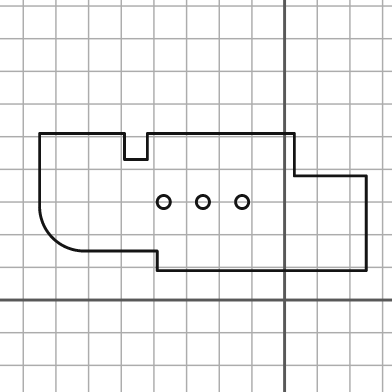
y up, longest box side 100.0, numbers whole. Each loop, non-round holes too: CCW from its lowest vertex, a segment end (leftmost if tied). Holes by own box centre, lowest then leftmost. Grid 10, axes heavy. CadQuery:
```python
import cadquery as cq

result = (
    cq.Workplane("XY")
    .moveTo(-39.0, 9.0)
    .lineTo(25.0, 9.0)
    .lineTo(25.0, 38.0)
    .lineTo(3.0, 38.0)
    .lineTo(3.0, 51.0)
    .lineTo(-42.0, 51.0)
    .lineTo(-42.0, 43.0)
    .lineTo(-49.0, 43.0)
    .lineTo(-49.0, 51.0)
    .lineTo(-75.0, 51.0)
    .lineTo(-75.0, 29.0)
    .threePointArc((-71.0, 19.0), (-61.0, 15.0))
    .lineTo(-39.0, 15.0)
    .close()
    .moveTo(-37.0, 30.0)
    .circle(2.0)
    .moveTo(-25.0, 30.0)
    .circle(2.0)
    .moveTo(-13.0, 30.0)
    .circle(2.0)
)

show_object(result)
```